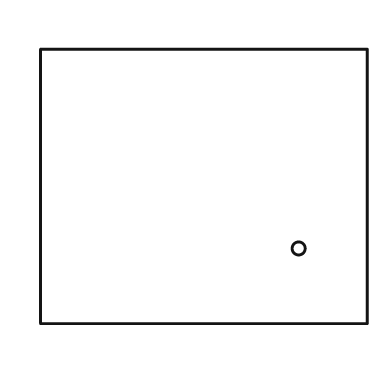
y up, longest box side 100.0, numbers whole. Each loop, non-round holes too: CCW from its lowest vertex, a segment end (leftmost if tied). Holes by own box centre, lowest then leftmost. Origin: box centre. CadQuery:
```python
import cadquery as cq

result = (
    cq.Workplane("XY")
    .moveTo(-50.0, -42.0)
    .lineTo(50.0, -42.0)
    .lineTo(50.0, 42.0)
    .lineTo(-50.0, 42.0)
    .close()
    .moveTo(29.0, -19.0)
    .circle(2.0)
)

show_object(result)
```